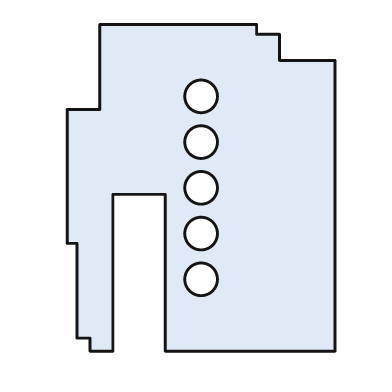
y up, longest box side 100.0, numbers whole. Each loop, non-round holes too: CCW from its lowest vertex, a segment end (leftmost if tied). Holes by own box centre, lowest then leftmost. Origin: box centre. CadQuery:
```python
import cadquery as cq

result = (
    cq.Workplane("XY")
    .moveTo(-34.0, -50.0)
    .lineTo(-27.0, -50.0)
    .lineTo(-27.0, -2.0)
    .lineTo(-11.0, -2.0)
    .lineTo(-11.0, -50.0)
    .lineTo(41.0, -50.0)
    .lineTo(41.0, 39.0)
    .lineTo(24.0, 39.0)
    .lineTo(24.0, 47.0)
    .lineTo(17.0, 47.0)
    .lineTo(17.0, 50.0)
    .lineTo(-31.0, 50.0)
    .lineTo(-31.0, 24.0)
    .lineTo(-41.0, 24.0)
    .lineTo(-41.0, -17.0)
    .lineTo(-38.0, -17.0)
    .lineTo(-38.0, -46.0)
    .lineTo(-34.0, -46.0)
    .close()
    .moveTo(0.0, -28.0)
    .circle(5.0)
    .moveTo(0.0, -14.0)
    .circle(5.0)
    .moveTo(0.0, 0.0)
    .circle(5.0)
    .moveTo(0.0, 14.0)
    .circle(5.0)
    .moveTo(0.0, 28.0)
    .circle(5.0)
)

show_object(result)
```